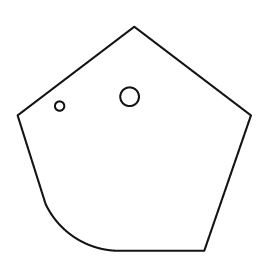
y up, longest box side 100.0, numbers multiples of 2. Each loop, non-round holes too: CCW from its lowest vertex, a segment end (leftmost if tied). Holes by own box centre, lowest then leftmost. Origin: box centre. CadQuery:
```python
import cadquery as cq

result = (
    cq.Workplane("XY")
    .moveTo(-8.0, -48.0)
    .lineTo(30.0, -48.0)
    .lineTo(50.0, 10.0)
    .lineTo(0.0, 48.0)
    .lineTo(-50.0, 10.0)
    .lineTo(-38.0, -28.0)
    .threePointArc((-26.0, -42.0), (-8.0, -48.0))
    .close()
    .moveTo(-32.0, 14.0)
    .circle(2.0)
    .moveTo(-2.0, 18.0)
    .circle(4.0)
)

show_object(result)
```